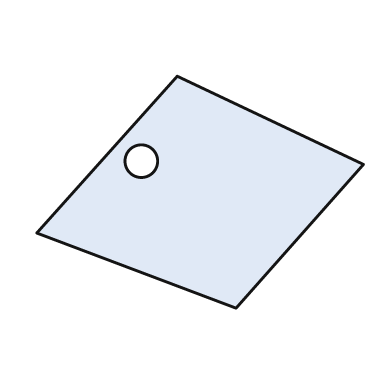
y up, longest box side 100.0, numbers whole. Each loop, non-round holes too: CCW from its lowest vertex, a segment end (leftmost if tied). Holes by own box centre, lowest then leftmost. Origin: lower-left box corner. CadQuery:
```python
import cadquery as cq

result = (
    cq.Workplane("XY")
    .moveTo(61.0, 0.0)
    .lineTo(100.0, 44.0)
    .lineTo(43.0, 71.0)
    .lineTo(0.0, 23.0)
    .close()
    .moveTo(32.0, 45.0)
    .circle(5.0)
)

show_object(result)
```